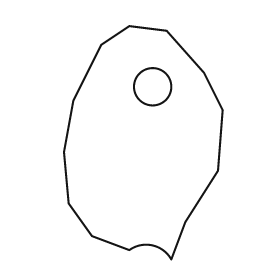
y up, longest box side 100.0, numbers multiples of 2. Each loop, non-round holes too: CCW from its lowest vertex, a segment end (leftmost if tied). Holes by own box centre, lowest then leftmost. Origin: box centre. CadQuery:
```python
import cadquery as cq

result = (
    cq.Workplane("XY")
    .moveTo(12.0, -50.0)
    .lineTo(18.0, -34.0)
    .lineTo(32.0, -12.0)
    .lineTo(34.0, 14.0)
    .lineTo(26.0, 30.0)
    .lineTo(10.0, 48.0)
    .lineTo(-6.0, 50.0)
    .lineTo(-18.0, 42.0)
    .lineTo(-30.0, 18.0)
    .lineTo(-34.0, -4.0)
    .lineTo(-32.0, -26.0)
    .lineTo(-22.0, -40.0)
    .lineTo(-6.0, -46.0)
    .threePointArc((4.0, -44.0), (12.0, -50.0))
    .close()
    .moveTo(4.0, 24.0)
    .circle(8.0)
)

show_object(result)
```